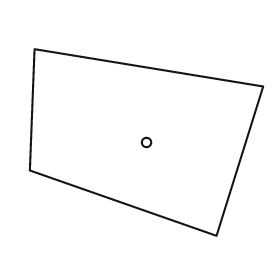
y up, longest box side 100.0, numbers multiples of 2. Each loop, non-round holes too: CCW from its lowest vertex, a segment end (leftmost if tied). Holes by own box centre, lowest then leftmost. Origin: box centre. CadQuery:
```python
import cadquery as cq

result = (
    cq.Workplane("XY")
    .moveTo(30.0, -40.0)
    .lineTo(50.0, 24.0)
    .lineTo(-48.0, 40.0)
    .lineTo(-50.0, -12.0)
    .close()
    .moveTo(0.0, 0.0)
    .circle(2.0)
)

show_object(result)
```